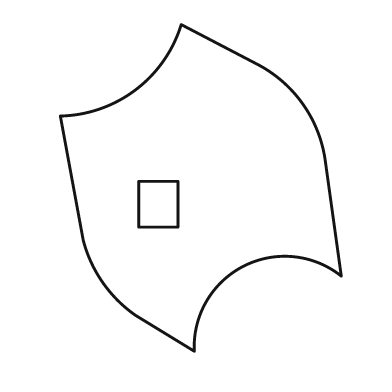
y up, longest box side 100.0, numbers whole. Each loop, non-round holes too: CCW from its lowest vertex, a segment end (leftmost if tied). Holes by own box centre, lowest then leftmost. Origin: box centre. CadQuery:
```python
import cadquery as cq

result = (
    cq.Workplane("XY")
    .moveTo(-2.0, -50.0)
    .threePointArc((13.0, -24.0), (43.0, -27.0))
    .lineTo(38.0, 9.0)
    .threePointArc((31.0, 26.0), (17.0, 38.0))
    .lineTo(-6.0, 50.0)
    .threePointArc((-20.0, 30.0), (-43.0, 22.0))
    .lineTo(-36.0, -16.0)
    .threePointArc((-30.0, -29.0), (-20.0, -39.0))
    .close()
    .moveTo(-19.0, -12.0)
    .lineTo(-7.0, -12.0)
    .lineTo(-7.0, 2.0)
    .lineTo(-19.0, 2.0)
    .close()
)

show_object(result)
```